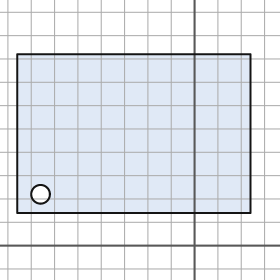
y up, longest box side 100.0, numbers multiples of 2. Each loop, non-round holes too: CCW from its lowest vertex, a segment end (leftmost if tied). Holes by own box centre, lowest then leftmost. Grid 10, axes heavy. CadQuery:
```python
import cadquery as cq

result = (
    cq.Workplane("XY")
    .moveTo(-76.0, 14.0)
    .lineTo(24.0, 14.0)
    .lineTo(24.0, 82.0)
    .lineTo(-76.0, 82.0)
    .close()
    .moveTo(-66.0, 22.0)
    .circle(4.0)
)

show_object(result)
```